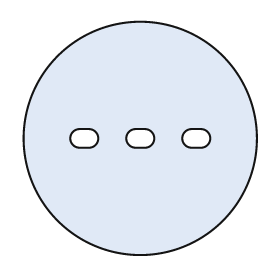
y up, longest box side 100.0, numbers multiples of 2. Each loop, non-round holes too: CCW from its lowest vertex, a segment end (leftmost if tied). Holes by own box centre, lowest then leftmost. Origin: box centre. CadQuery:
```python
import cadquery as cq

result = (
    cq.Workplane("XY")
    .moveTo(0.0, 0.0)
    .circle(50.0)
    .moveTo(-26.0, -4.0)
    .lineTo(-22.0, -4.0)
    .threePointArc((-18.0, 0.0), (-22.0, 4.0))
    .lineTo(-26.0, 4.0)
    .threePointArc((-30.0, 0.0), (-26.0, -4.0))
    .close()
    .moveTo(-2.0, -4.0)
    .lineTo(2.0, -4.0)
    .threePointArc((6.0, 0.0), (2.0, 4.0))
    .lineTo(-2.0, 4.0)
    .threePointArc((-6.0, 0.0), (-2.0, -4.0))
    .close()
    .moveTo(22.0, -4.0)
    .lineTo(26.0, -4.0)
    .threePointArc((30.0, 0.0), (26.0, 4.0))
    .lineTo(22.0, 4.0)
    .threePointArc((18.0, 0.0), (22.0, -4.0))
    .close()
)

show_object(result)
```